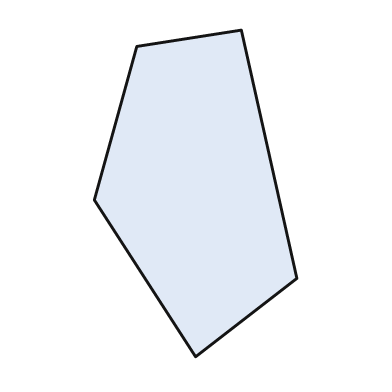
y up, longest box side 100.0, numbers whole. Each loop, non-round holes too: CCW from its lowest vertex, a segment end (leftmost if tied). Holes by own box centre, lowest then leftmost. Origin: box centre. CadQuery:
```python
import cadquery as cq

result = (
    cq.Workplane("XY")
    .moveTo(0.0, -50.0)
    .lineTo(31.0, -26.0)
    .lineTo(14.0, 50.0)
    .lineTo(-18.0, 45.0)
    .lineTo(-31.0, -2.0)
    .close()
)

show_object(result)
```